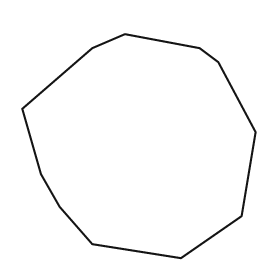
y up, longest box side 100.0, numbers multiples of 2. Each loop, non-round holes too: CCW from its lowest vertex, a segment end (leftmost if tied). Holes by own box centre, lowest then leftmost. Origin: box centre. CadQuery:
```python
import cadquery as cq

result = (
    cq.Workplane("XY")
    .moveTo(18.0, -48.0)
    .lineTo(44.0, -30.0)
    .lineTo(50.0, 6.0)
    .lineTo(34.0, 36.0)
    .lineTo(26.0, 42.0)
    .lineTo(-6.0, 48.0)
    .lineTo(-20.0, 42.0)
    .lineTo(-50.0, 16.0)
    .lineTo(-42.0, -12.0)
    .lineTo(-34.0, -26.0)
    .lineTo(-20.0, -42.0)
    .close()
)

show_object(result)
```